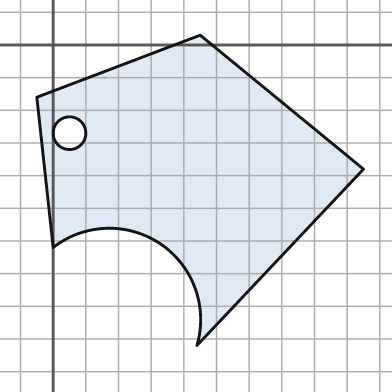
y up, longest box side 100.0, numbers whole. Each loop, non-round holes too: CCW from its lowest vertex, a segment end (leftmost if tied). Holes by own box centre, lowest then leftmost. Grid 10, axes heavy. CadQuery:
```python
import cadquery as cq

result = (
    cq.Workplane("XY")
    .moveTo(44.0, -92.0)
    .lineTo(95.0, -38.0)
    .lineTo(45.0, 3.0)
    .lineTo(-5.0, -16.0)
    .lineTo(0.0, -62.0)
    .threePointArc((33.0, -61.0), (44.0, -92.0))
    .close()
    .moveTo(5.0, -27.0)
    .circle(5.0)
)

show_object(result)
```